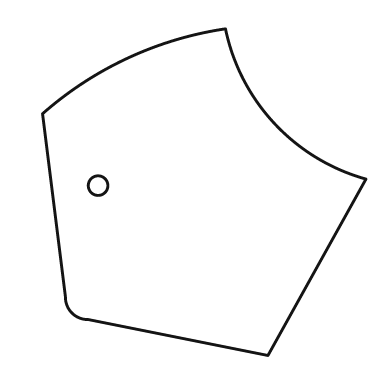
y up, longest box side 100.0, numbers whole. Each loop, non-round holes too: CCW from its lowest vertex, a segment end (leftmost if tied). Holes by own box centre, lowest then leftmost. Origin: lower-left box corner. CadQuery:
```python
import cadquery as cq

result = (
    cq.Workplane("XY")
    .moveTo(69.0, 0.0)
    .lineTo(99.0, 54.0)
    .threePointArc((71.0, 71.0), (56.0, 100.0))
    .threePointArc((26.0, 91.0), (0.0, 74.0))
    .lineTo(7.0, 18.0)
    .threePointArc((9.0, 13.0), (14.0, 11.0))
    .close()
    .moveTo(17.0, 52.0)
    .circle(3.0)
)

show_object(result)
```